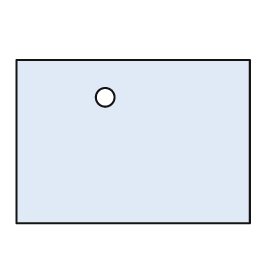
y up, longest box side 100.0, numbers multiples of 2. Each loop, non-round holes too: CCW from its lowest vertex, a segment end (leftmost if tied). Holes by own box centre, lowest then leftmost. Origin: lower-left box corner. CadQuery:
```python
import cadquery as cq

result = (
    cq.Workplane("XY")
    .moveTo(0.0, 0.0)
    .lineTo(100.0, 0.0)
    .lineTo(100.0, 70.0)
    .lineTo(0.0, 70.0)
    .close()
    .moveTo(38.0, 54.0)
    .circle(4.0)
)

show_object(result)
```